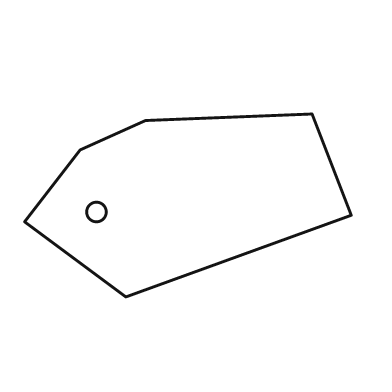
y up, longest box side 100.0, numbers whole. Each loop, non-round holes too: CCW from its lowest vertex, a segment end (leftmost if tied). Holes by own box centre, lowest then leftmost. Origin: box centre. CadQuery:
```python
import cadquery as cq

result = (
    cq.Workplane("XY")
    .moveTo(-19.0, -28.0)
    .lineTo(50.0, -3.0)
    .lineTo(38.0, 28.0)
    .lineTo(-13.0, 26.0)
    .lineTo(-33.0, 17.0)
    .lineTo(-50.0, -5.0)
    .close()
    .moveTo(-28.0, -2.0)
    .circle(3.0)
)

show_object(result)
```